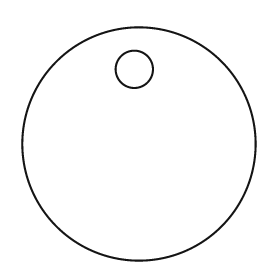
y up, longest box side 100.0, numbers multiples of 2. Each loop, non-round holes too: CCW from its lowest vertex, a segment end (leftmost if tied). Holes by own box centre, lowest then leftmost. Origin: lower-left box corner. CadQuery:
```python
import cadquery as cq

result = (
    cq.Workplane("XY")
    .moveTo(50.0, 50.0)
    .circle(50.0)
    .moveTo(48.0, 82.0)
    .circle(8.0)
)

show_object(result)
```